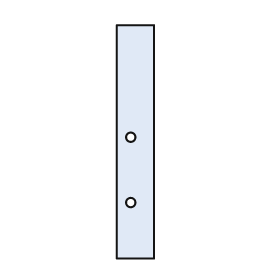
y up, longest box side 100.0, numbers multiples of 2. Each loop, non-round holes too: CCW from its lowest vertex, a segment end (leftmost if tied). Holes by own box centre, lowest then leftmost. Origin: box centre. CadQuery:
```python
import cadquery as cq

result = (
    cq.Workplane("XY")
    .moveTo(-8.0, -50.0)
    .lineTo(8.0, -50.0)
    .lineTo(8.0, 50.0)
    .lineTo(-8.0, 50.0)
    .close()
    .moveTo(-2.0, -26.0)
    .circle(2.0)
    .moveTo(-2.0, 2.0)
    .circle(2.0)
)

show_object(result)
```